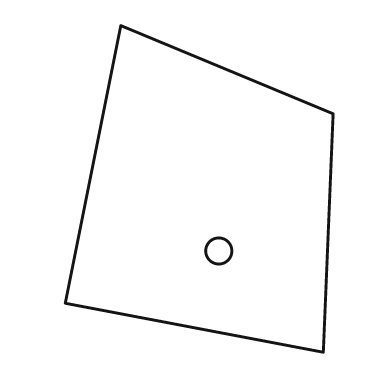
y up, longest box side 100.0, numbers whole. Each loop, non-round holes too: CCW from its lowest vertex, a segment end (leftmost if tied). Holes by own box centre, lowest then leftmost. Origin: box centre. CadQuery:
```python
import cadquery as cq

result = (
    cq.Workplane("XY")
    .moveTo(38.0, -50.0)
    .lineTo(41.0, 23.0)
    .lineTo(-24.0, 50.0)
    .lineTo(-41.0, -35.0)
    .close()
    .moveTo(6.0, -19.0)
    .circle(4.0)
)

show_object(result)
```